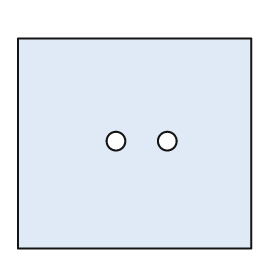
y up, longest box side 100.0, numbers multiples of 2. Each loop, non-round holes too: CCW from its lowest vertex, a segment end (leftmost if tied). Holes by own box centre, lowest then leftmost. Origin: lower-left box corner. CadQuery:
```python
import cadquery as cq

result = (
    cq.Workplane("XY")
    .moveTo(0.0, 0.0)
    .lineTo(100.0, 0.0)
    .lineTo(100.0, 90.0)
    .lineTo(0.0, 90.0)
    .close()
    .moveTo(42.0, 46.0)
    .circle(4.0)
    .moveTo(64.0, 46.0)
    .circle(4.0)
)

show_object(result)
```